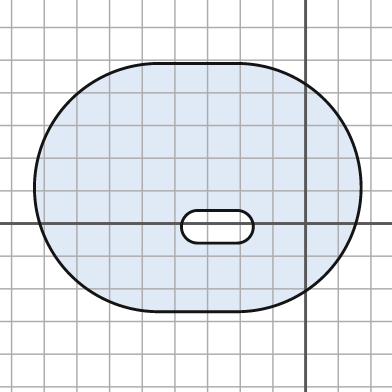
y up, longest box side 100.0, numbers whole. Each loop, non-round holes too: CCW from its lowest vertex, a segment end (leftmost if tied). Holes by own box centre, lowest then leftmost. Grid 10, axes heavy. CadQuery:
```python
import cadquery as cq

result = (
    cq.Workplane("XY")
    .moveTo(-45.0, -27.0)
    .lineTo(-21.0, -27.0)
    .threePointArc((17.0, 11.0), (-21.0, 49.0))
    .lineTo(-45.0, 49.0)
    .threePointArc((-83.0, 11.0), (-45.0, -27.0))
    .close()
    .moveTo(-33.0, -6.0)
    .lineTo(-21.0, -6.0)
    .threePointArc((-16.0, -1.0), (-21.0, 4.0))
    .lineTo(-33.0, 4.0)
    .threePointArc((-38.0, -1.0), (-33.0, -6.0))
    .close()
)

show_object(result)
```